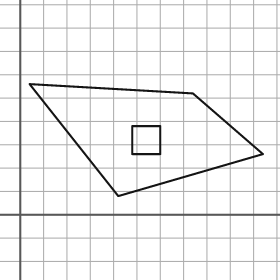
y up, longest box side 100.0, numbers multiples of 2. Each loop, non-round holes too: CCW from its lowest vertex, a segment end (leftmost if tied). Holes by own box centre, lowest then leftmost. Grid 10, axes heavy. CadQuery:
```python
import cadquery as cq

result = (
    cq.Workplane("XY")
    .moveTo(42.0, 8.0)
    .lineTo(104.0, 26.0)
    .lineTo(74.0, 52.0)
    .lineTo(4.0, 56.0)
    .close()
    .moveTo(48.0, 26.0)
    .lineTo(60.0, 26.0)
    .lineTo(60.0, 38.0)
    .lineTo(48.0, 38.0)
    .close()
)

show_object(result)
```